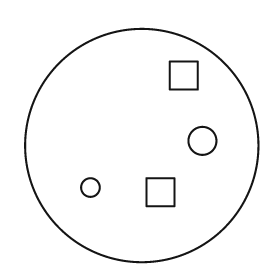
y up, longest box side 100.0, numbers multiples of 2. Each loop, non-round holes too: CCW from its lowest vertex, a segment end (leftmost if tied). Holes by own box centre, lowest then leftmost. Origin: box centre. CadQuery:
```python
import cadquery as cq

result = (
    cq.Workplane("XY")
    .moveTo(0.0, 0.0)
    .circle(50.0)
    .moveTo(2.0, -26.0)
    .lineTo(14.0, -26.0)
    .lineTo(14.0, -14.0)
    .lineTo(2.0, -14.0)
    .close()
    .moveTo(-22.0, -18.0)
    .circle(4.0)
    .moveTo(26.0, 2.0)
    .circle(6.0)
    .moveTo(12.0, 24.0)
    .lineTo(24.0, 24.0)
    .lineTo(24.0, 36.0)
    .lineTo(12.0, 36.0)
    .close()
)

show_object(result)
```